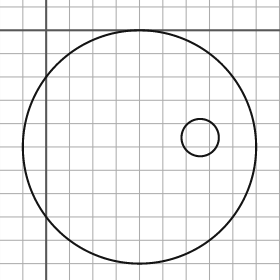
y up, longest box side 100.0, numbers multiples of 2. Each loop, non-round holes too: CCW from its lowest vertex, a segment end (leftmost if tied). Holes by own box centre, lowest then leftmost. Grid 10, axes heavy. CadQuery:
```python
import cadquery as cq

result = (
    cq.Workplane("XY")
    .moveTo(40.0, -50.0)
    .circle(50.0)
    .moveTo(66.0, -46.0)
    .circle(8.0)
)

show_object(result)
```